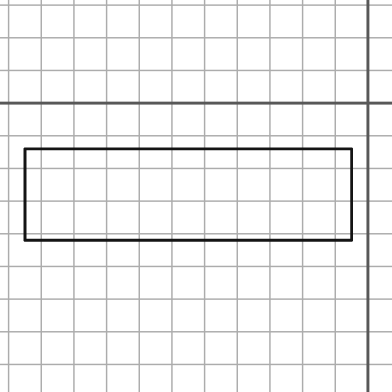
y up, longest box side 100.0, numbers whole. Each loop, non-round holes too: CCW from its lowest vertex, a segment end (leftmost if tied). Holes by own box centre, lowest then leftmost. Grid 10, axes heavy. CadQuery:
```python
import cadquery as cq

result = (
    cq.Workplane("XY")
    .moveTo(-105.0, -42.0)
    .lineTo(-5.0, -42.0)
    .lineTo(-5.0, -14.0)
    .lineTo(-105.0, -14.0)
    .close()
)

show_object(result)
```